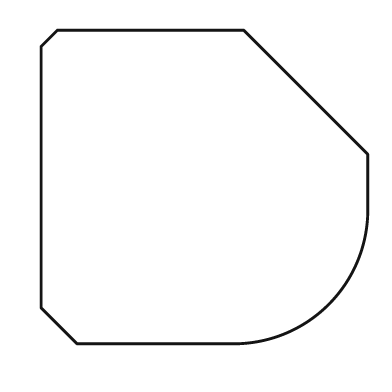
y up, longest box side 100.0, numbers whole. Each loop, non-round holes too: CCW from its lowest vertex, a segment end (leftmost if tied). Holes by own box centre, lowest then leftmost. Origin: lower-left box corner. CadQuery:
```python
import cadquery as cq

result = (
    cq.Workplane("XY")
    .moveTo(11.0, 0.0)
    .lineTo(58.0, 0.0)
    .threePointArc((88.0, 12.0), (100.0, 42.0))
    .lineTo(100.0, 58.0)
    .lineTo(62.0, 96.0)
    .lineTo(5.0, 96.0)
    .lineTo(0.0, 91.0)
    .lineTo(0.0, 11.0)
    .close()
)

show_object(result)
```